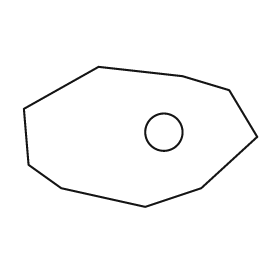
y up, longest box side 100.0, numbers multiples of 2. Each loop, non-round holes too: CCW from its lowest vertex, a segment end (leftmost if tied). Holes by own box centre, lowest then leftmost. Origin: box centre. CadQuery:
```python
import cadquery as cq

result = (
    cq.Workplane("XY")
    .moveTo(2.0, -30.0)
    .lineTo(26.0, -22.0)
    .lineTo(50.0, 0.0)
    .lineTo(38.0, 20.0)
    .lineTo(18.0, 26.0)
    .lineTo(-18.0, 30.0)
    .lineTo(-50.0, 12.0)
    .lineTo(-48.0, -12.0)
    .lineTo(-34.0, -22.0)
    .close()
    .moveTo(10.0, 2.0)
    .circle(8.0)
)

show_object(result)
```